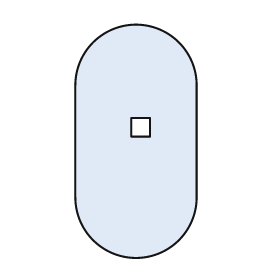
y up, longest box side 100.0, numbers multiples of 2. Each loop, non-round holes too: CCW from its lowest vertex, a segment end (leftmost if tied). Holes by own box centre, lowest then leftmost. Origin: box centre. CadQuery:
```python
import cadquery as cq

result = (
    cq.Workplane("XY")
    .moveTo(-26.0, -24.0)
    .threePointArc((0.0, -50.0), (26.0, -24.0))
    .lineTo(26.0, 24.0)
    .threePointArc((0.0, 50.0), (-26.0, 24.0))
    .close()
    .moveTo(-2.0, 2.0)
    .lineTo(6.0, 2.0)
    .lineTo(6.0, 10.0)
    .lineTo(-2.0, 10.0)
    .close()
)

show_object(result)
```